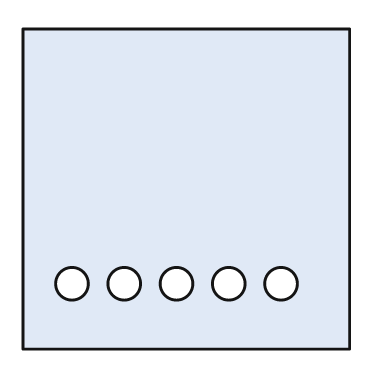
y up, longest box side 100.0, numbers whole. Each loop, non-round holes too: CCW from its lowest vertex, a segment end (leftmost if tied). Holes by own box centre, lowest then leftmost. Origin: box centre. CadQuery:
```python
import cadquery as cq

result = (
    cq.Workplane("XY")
    .moveTo(-50.0, -49.0)
    .lineTo(50.0, -49.0)
    .lineTo(50.0, 49.0)
    .lineTo(-50.0, 49.0)
    .close()
    .moveTo(-35.0, -29.0)
    .circle(5.0)
    .moveTo(-19.0, -29.0)
    .circle(5.0)
    .moveTo(-3.0, -29.0)
    .circle(5.0)
    .moveTo(13.0, -29.0)
    .circle(5.0)
    .moveTo(29.0, -29.0)
    .circle(5.0)
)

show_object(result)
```